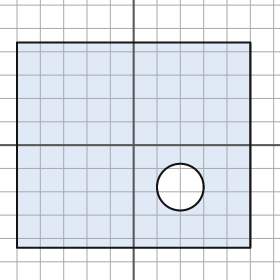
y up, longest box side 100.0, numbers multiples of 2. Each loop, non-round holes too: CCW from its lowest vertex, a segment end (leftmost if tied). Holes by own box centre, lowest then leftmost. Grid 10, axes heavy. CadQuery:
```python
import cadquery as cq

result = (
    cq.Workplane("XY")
    .moveTo(-50.0, -44.0)
    .lineTo(50.0, -44.0)
    .lineTo(50.0, 44.0)
    .lineTo(-50.0, 44.0)
    .close()
    .moveTo(20.0, -18.0)
    .circle(10.0)
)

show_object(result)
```